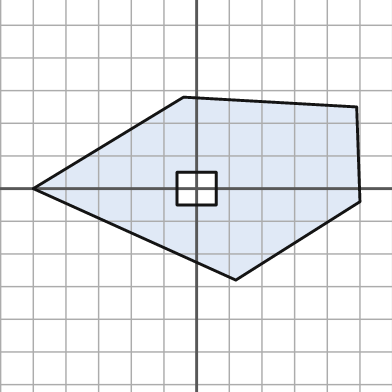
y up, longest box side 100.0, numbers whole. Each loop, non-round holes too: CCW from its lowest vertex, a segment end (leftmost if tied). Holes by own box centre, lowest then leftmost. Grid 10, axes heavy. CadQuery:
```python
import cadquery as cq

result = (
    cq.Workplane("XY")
    .moveTo(12.0, -28.0)
    .lineTo(50.0, -4.0)
    .lineTo(49.0, 25.0)
    .lineTo(-4.0, 28.0)
    .lineTo(-50.0, 0.0)
    .close()
    .moveTo(-6.0, -5.0)
    .lineTo(6.0, -5.0)
    .lineTo(6.0, 5.0)
    .lineTo(-6.0, 5.0)
    .close()
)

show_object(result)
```